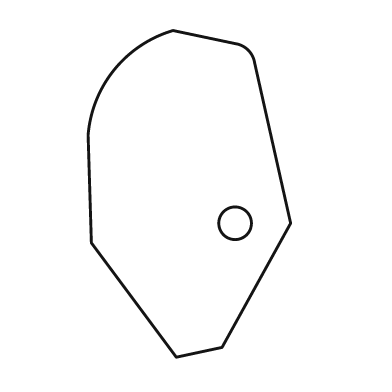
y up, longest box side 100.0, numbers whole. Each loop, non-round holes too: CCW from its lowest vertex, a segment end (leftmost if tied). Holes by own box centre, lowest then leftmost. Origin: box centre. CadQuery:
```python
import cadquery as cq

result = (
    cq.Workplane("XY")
    .moveTo(-4.0, -50.0)
    .lineTo(10.0, -47.0)
    .lineTo(31.0, -9.0)
    .lineTo(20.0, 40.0)
    .threePointArc((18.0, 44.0), (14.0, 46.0))
    .lineTo(-5.0, 50.0)
    .threePointArc((-23.0, 38.0), (-31.0, 18.0))
    .lineTo(-30.0, -15.0)
    .close()
    .moveTo(14.0, -9.0)
    .circle(5.0)
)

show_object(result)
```